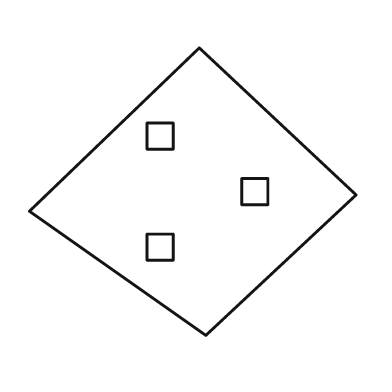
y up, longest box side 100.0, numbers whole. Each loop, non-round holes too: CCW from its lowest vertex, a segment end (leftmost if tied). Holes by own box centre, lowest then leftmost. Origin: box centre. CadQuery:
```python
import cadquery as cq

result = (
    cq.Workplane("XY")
    .moveTo(4.0, -44.0)
    .lineTo(50.0, -1.0)
    .lineTo(2.0, 44.0)
    .lineTo(-50.0, -6.0)
    .close()
    .moveTo(-14.0, -21.0)
    .lineTo(-6.0, -21.0)
    .lineTo(-6.0, -13.0)
    .lineTo(-14.0, -13.0)
    .close()
    .moveTo(15.0, -4.0)
    .lineTo(23.0, -4.0)
    .lineTo(23.0, 4.0)
    .lineTo(15.0, 4.0)
    .close()
    .moveTo(-14.0, 13.0)
    .lineTo(-6.0, 13.0)
    .lineTo(-6.0, 21.0)
    .lineTo(-14.0, 21.0)
    .close()
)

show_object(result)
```